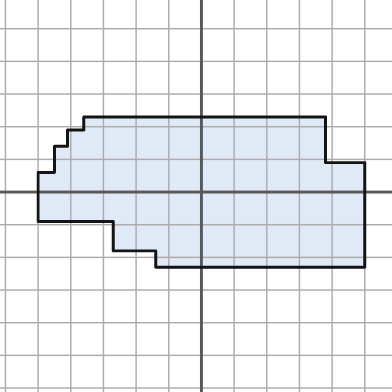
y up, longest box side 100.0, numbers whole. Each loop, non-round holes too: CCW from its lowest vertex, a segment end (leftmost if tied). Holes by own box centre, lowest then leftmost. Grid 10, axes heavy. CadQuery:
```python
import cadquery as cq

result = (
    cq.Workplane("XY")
    .moveTo(-14.0, -23.0)
    .lineTo(50.0, -23.0)
    .lineTo(50.0, 9.0)
    .lineTo(38.0, 9.0)
    .lineTo(38.0, 23.0)
    .lineTo(-36.0, 23.0)
    .lineTo(-36.0, 19.0)
    .lineTo(-41.0, 19.0)
    .lineTo(-41.0, 14.0)
    .lineTo(-45.0, 14.0)
    .lineTo(-45.0, 6.0)
    .lineTo(-50.0, 6.0)
    .lineTo(-50.0, -9.0)
    .lineTo(-27.0, -9.0)
    .lineTo(-27.0, -18.0)
    .lineTo(-14.0, -18.0)
    .close()
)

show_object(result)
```